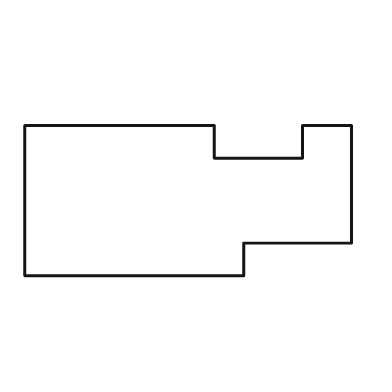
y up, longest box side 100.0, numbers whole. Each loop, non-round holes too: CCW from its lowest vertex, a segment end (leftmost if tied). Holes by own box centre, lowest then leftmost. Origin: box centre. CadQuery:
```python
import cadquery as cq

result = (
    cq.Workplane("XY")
    .moveTo(-50.0, -23.0)
    .lineTo(17.0, -23.0)
    .lineTo(17.0, -13.0)
    .lineTo(50.0, -13.0)
    .lineTo(50.0, 23.0)
    .lineTo(35.0, 23.0)
    .lineTo(35.0, 13.0)
    .lineTo(8.0, 13.0)
    .lineTo(8.0, 23.0)
    .lineTo(-50.0, 23.0)
    .close()
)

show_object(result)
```